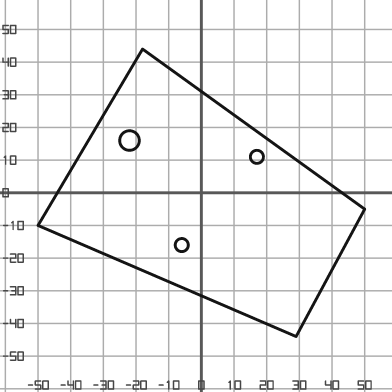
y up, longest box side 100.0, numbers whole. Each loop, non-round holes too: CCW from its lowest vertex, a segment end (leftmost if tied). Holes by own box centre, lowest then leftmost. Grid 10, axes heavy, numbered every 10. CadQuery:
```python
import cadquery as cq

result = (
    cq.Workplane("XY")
    .moveTo(29.0, -44.0)
    .lineTo(50.0, -5.0)
    .lineTo(-18.0, 44.0)
    .lineTo(-50.0, -10.0)
    .close()
    .moveTo(-6.0, -16.0)
    .circle(2.0)
    .moveTo(17.0, 11.0)
    .circle(2.0)
    .moveTo(-22.0, 16.0)
    .circle(3.0)
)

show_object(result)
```